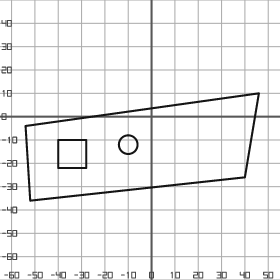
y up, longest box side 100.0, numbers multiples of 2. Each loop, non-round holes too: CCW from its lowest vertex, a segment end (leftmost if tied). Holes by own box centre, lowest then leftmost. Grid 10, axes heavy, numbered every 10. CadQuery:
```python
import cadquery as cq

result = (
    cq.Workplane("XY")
    .moveTo(-52.0, -36.0)
    .lineTo(40.0, -26.0)
    .lineTo(46.0, 10.0)
    .lineTo(-54.0, -4.0)
    .close()
    .moveTo(-40.0, -22.0)
    .lineTo(-28.0, -22.0)
    .lineTo(-28.0, -10.0)
    .lineTo(-40.0, -10.0)
    .close()
    .moveTo(-10.0, -12.0)
    .circle(4.0)
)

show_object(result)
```